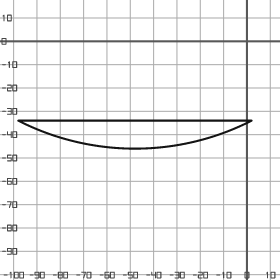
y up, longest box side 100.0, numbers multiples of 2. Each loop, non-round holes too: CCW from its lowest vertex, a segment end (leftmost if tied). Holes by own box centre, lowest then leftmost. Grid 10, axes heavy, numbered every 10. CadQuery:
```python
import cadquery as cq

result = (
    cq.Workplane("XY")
    .moveTo(-98.0, -34.0)
    .threePointArc((-48.0, -46.0), (2.0, -34.0))
    .close()
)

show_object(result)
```